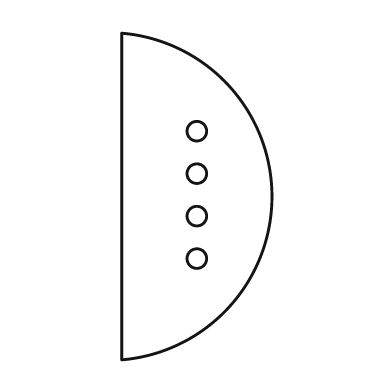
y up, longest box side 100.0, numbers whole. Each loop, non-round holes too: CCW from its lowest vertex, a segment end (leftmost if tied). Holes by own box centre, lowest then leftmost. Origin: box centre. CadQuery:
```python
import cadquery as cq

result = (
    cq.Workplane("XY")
    .moveTo(-23.0, -50.0)
    .threePointArc((23.0, 0.0), (-23.0, 50.0))
    .close()
    .moveTo(0.0, -19.0)
    .circle(3.0)
    .moveTo(0.0, -6.0)
    .circle(3.0)
    .moveTo(0.0, 7.0)
    .circle(3.0)
    .moveTo(0.0, 20.0)
    .circle(3.0)
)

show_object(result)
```